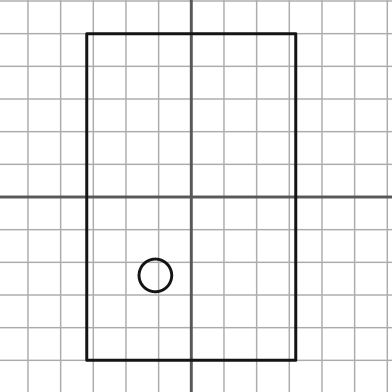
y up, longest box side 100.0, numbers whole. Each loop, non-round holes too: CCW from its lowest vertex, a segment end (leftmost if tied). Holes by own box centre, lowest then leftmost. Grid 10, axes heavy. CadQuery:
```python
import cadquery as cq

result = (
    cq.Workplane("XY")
    .moveTo(-32.0, -50.0)
    .lineTo(32.0, -50.0)
    .lineTo(32.0, 50.0)
    .lineTo(-32.0, 50.0)
    .close()
    .moveTo(-11.0, -24.0)
    .circle(5.0)
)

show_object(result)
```